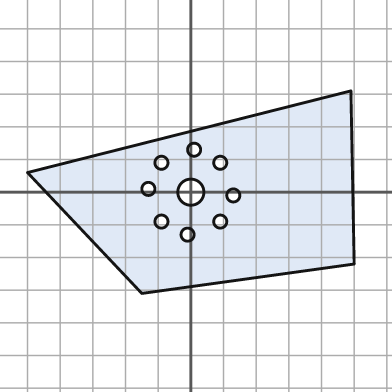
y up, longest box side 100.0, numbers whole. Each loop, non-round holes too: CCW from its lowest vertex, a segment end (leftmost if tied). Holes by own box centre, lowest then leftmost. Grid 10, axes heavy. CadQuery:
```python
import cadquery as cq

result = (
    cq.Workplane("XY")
    .moveTo(-15.0, -31.0)
    .lineTo(50.0, -22.0)
    .lineTo(49.0, 31.0)
    .lineTo(-50.0, 6.0)
    .close()
    .moveTo(-1.0, -13.0)
    .circle(2.0)
    .moveTo(-9.0, -9.0)
    .circle(2.0)
    .moveTo(9.0, -9.0)
    .circle(2.0)
    .moveTo(13.0, -1.0)
    .circle(2.0)
    .moveTo(0.0, 0.0)
    .circle(4.0)
    .moveTo(-13.0, 1.0)
    .circle(2.0)
    .moveTo(-9.0, 9.0)
    .circle(2.0)
    .moveTo(9.0, 9.0)
    .circle(2.0)
    .moveTo(1.0, 13.0)
    .circle(2.0)
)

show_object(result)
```